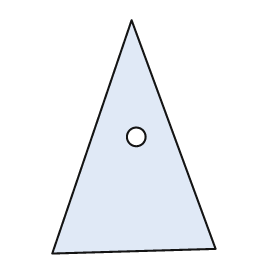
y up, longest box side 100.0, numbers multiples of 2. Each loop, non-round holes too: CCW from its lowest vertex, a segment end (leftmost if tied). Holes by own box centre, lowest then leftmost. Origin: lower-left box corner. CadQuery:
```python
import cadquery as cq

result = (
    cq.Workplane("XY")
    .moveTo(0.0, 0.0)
    .lineTo(70.0, 2.0)
    .lineTo(34.0, 100.0)
    .close()
    .moveTo(36.0, 50.0)
    .circle(4.0)
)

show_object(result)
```